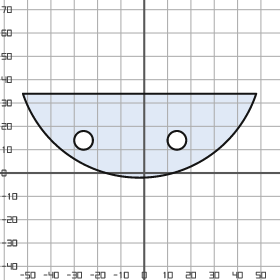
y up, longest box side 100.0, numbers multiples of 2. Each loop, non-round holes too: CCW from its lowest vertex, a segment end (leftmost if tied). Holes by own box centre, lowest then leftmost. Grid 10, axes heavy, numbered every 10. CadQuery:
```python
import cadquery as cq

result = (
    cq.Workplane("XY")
    .moveTo(-52.0, 34.0)
    .threePointArc((-2.0, -2.0), (48.0, 34.0))
    .close()
    .moveTo(-26.0, 14.0)
    .circle(4.0)
    .moveTo(14.0, 14.0)
    .circle(4.0)
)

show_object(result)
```